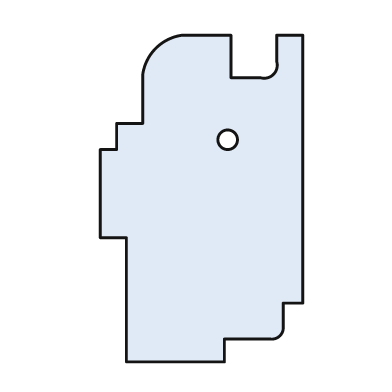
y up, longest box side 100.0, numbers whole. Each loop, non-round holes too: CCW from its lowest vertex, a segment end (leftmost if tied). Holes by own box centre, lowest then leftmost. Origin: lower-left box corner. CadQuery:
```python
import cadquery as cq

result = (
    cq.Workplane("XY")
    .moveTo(8.0, 0.0)
    .lineTo(38.0, 0.0)
    .lineTo(38.0, 7.0)
    .lineTo(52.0, 7.0)
    .threePointArc((55.0, 8.0), (56.0, 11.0))
    .lineTo(56.0, 18.0)
    .lineTo(62.0, 18.0)
    .lineTo(62.0, 100.0)
    .lineTo(54.0, 100.0)
    .lineTo(54.0, 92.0)
    .threePointArc((53.0, 88.0), (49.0, 87.0))
    .lineTo(40.0, 87.0)
    .lineTo(40.0, 100.0)
    .lineTo(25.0, 100.0)
    .threePointArc((17.0, 96.0), (13.0, 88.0))
    .lineTo(13.0, 73.0)
    .lineTo(5.0, 73.0)
    .lineTo(5.0, 65.0)
    .lineTo(0.0, 65.0)
    .lineTo(0.0, 38.0)
    .lineTo(8.0, 38.0)
    .close()
    .moveTo(39.0, 68.0)
    .circle(3.0)
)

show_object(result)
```